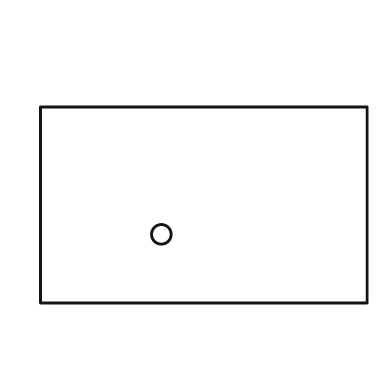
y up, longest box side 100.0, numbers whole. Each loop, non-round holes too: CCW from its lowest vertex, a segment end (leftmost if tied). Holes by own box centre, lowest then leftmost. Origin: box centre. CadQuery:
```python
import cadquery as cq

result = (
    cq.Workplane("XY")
    .moveTo(-50.0, -30.0)
    .lineTo(50.0, -30.0)
    .lineTo(50.0, 30.0)
    .lineTo(-50.0, 30.0)
    .close()
    .moveTo(-13.0, -9.0)
    .circle(3.0)
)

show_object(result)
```